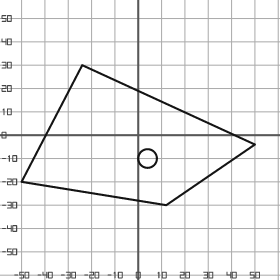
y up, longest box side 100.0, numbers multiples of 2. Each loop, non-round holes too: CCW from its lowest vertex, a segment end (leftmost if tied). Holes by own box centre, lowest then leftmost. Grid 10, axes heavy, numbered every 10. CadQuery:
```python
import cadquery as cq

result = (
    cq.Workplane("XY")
    .moveTo(12.0, -30.0)
    .lineTo(50.0, -4.0)
    .lineTo(-24.0, 30.0)
    .lineTo(-50.0, -20.0)
    .close()
    .moveTo(4.0, -10.0)
    .circle(4.0)
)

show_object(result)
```